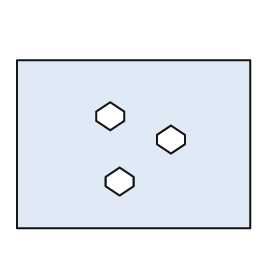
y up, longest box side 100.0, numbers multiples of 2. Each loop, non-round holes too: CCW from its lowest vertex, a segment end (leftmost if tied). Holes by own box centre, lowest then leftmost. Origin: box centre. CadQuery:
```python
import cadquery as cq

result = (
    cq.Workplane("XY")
    .moveTo(-50.0, -36.0)
    .lineTo(50.0, -36.0)
    .lineTo(50.0, 36.0)
    .lineTo(-50.0, 36.0)
    .close()
    .moveTo(-6.0, -22.0)
    .lineTo(0.0, -18.0)
    .lineTo(0.0, -14.0)
    .lineTo(-6.0, -10.0)
    .lineTo(-12.0, -14.0)
    .lineTo(-12.0, -18.0)
    .close()
    .moveTo(16.0, -4.0)
    .lineTo(22.0, 0.0)
    .lineTo(22.0, 4.0)
    .lineTo(16.0, 8.0)
    .lineTo(10.0, 4.0)
    .lineTo(10.0, 0.0)
    .close()
    .moveTo(-10.0, 6.0)
    .lineTo(-4.0, 10.0)
    .lineTo(-4.0, 14.0)
    .lineTo(-10.0, 18.0)
    .lineTo(-16.0, 14.0)
    .lineTo(-16.0, 10.0)
    .close()
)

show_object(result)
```